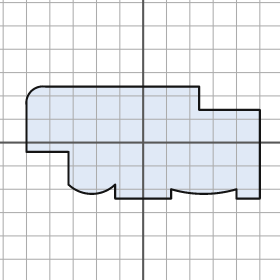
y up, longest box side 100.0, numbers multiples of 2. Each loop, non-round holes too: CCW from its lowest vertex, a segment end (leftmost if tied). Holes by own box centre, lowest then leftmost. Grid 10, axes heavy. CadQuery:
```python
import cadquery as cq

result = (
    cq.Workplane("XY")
    .moveTo(-12.0, -24.0)
    .lineTo(12.0, -24.0)
    .lineTo(12.0, -20.0)
    .threePointArc((26.0, -22.0), (40.0, -20.0))
    .lineTo(40.0, -24.0)
    .lineTo(50.0, -24.0)
    .lineTo(50.0, 14.0)
    .lineTo(24.0, 14.0)
    .lineTo(24.0, 24.0)
    .lineTo(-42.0, 24.0)
    .threePointArc((-48.0, 22.0), (-50.0, 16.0))
    .lineTo(-50.0, -4.0)
    .lineTo(-32.0, -4.0)
    .lineTo(-32.0, -18.0)
    .threePointArc((-22.0, -22.0), (-12.0, -18.0))
    .close()
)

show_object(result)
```